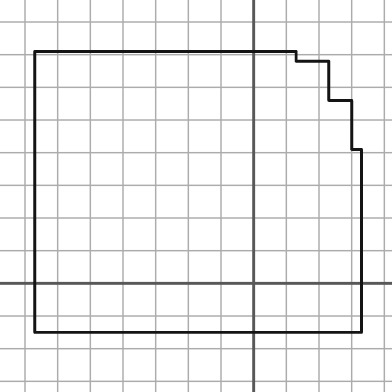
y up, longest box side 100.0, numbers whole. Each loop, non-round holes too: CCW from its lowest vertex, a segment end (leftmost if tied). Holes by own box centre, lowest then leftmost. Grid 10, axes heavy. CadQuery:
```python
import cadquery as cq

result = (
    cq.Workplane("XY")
    .moveTo(-67.0, -15.0)
    .lineTo(33.0, -15.0)
    .lineTo(33.0, 41.0)
    .lineTo(30.0, 41.0)
    .lineTo(30.0, 56.0)
    .lineTo(23.0, 56.0)
    .lineTo(23.0, 68.0)
    .lineTo(13.0, 68.0)
    .lineTo(13.0, 71.0)
    .lineTo(-67.0, 71.0)
    .close()
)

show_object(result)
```